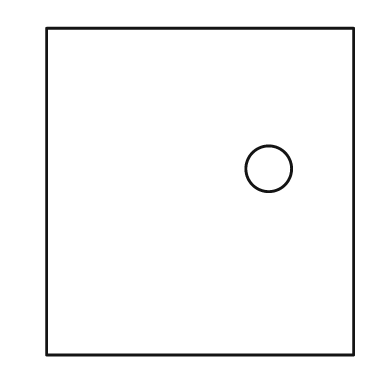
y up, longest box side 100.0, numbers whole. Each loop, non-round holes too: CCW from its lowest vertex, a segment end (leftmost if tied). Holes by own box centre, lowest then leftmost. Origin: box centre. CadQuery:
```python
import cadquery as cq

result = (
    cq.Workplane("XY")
    .moveTo(-47.0, -50.0)
    .lineTo(47.0, -50.0)
    .lineTo(47.0, 50.0)
    .lineTo(-47.0, 50.0)
    .close()
    .moveTo(21.0, 7.0)
    .circle(7.0)
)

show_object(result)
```